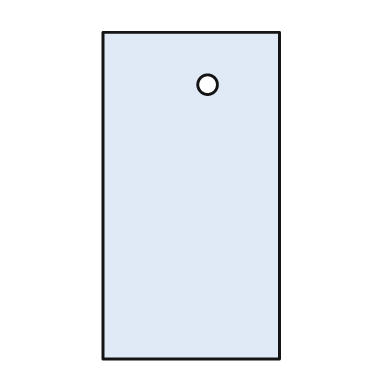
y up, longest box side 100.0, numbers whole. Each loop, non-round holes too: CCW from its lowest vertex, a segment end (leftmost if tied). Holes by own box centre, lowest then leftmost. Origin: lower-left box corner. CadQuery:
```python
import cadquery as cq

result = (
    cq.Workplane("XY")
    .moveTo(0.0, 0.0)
    .lineTo(54.0, 0.0)
    .lineTo(54.0, 100.0)
    .lineTo(0.0, 100.0)
    .close()
    .moveTo(32.0, 84.0)
    .circle(3.0)
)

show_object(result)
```